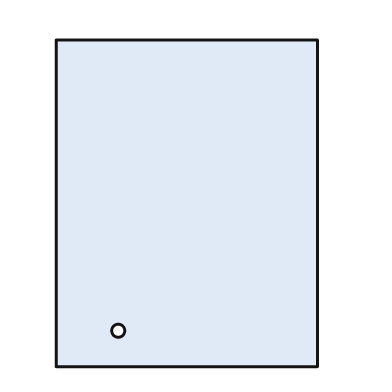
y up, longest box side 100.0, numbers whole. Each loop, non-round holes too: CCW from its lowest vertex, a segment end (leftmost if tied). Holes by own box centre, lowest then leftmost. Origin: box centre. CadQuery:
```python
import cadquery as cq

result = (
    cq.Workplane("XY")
    .moveTo(-40.0, -50.0)
    .lineTo(40.0, -50.0)
    .lineTo(40.0, 50.0)
    .lineTo(-40.0, 50.0)
    .close()
    .moveTo(-21.0, -39.0)
    .circle(2.0)
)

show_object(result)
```